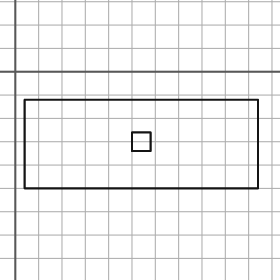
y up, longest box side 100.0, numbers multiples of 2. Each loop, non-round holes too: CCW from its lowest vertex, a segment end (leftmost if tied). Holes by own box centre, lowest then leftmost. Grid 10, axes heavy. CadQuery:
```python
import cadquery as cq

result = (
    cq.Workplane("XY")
    .moveTo(4.0, -50.0)
    .lineTo(104.0, -50.0)
    .lineTo(104.0, -12.0)
    .lineTo(4.0, -12.0)
    .close()
    .moveTo(50.0, -34.0)
    .lineTo(58.0, -34.0)
    .lineTo(58.0, -26.0)
    .lineTo(50.0, -26.0)
    .close()
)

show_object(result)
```